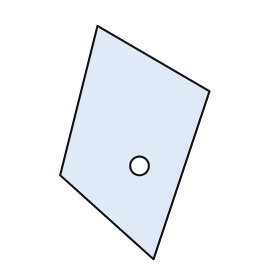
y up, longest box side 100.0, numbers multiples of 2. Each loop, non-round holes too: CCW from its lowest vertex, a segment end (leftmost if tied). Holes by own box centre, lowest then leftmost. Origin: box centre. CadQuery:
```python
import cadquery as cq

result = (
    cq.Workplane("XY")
    .moveTo(8.0, -50.0)
    .lineTo(32.0, 22.0)
    .lineTo(-16.0, 50.0)
    .lineTo(-32.0, -14.0)
    .close()
    .moveTo(2.0, -10.0)
    .circle(4.0)
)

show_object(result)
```